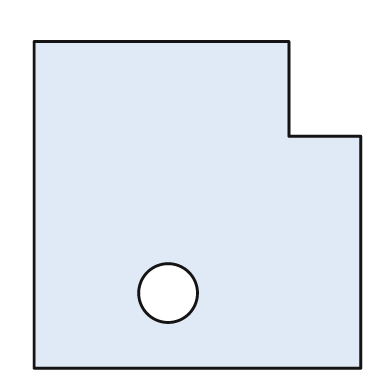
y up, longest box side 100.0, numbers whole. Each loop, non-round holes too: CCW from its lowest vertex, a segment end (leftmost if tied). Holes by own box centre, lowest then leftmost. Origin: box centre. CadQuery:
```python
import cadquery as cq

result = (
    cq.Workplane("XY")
    .moveTo(-50.0, -50.0)
    .lineTo(50.0, -50.0)
    .lineTo(50.0, 21.0)
    .lineTo(28.0, 21.0)
    .lineTo(28.0, 50.0)
    .lineTo(-50.0, 50.0)
    .close()
    .moveTo(-9.0, -27.0)
    .circle(9.0)
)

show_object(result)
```